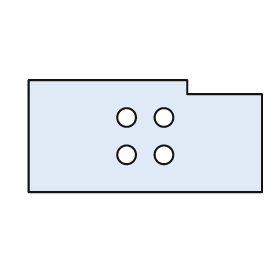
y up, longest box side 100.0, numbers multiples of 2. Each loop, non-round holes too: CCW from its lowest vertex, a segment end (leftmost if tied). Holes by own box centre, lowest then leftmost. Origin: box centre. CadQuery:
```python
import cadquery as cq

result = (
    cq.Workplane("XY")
    .moveTo(-50.0, -24.0)
    .lineTo(50.0, -24.0)
    .lineTo(50.0, 18.0)
    .lineTo(18.0, 18.0)
    .lineTo(18.0, 24.0)
    .lineTo(-50.0, 24.0)
    .close()
    .moveTo(-8.0, -8.0)
    .circle(4.0)
    .moveTo(8.0, -8.0)
    .circle(4.0)
    .moveTo(-8.0, 8.0)
    .circle(4.0)
    .moveTo(8.0, 8.0)
    .circle(4.0)
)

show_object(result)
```